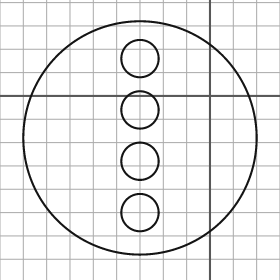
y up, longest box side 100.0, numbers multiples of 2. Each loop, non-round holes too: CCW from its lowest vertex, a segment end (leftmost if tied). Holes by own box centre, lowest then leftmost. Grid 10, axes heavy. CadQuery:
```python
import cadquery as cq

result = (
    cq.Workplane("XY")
    .moveTo(-30.0, -18.0)
    .circle(50.0)
    .moveTo(-30.0, -50.0)
    .circle(8.0)
    .moveTo(-30.0, -28.0)
    .circle(8.0)
    .moveTo(-30.0, -6.0)
    .circle(8.0)
    .moveTo(-30.0, 16.0)
    .circle(8.0)
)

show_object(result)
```